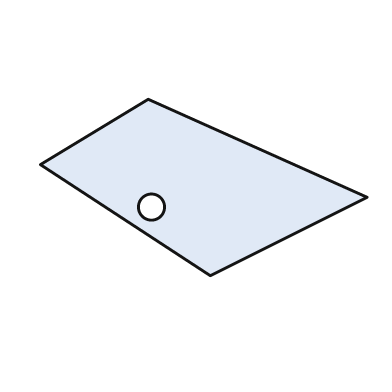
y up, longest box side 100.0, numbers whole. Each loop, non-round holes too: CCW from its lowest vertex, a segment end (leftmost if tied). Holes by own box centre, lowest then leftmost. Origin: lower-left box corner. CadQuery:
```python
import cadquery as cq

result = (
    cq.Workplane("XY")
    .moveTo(52.0, 0.0)
    .lineTo(100.0, 24.0)
    .lineTo(33.0, 54.0)
    .lineTo(0.0, 34.0)
    .close()
    .moveTo(34.0, 21.0)
    .circle(4.0)
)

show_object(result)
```